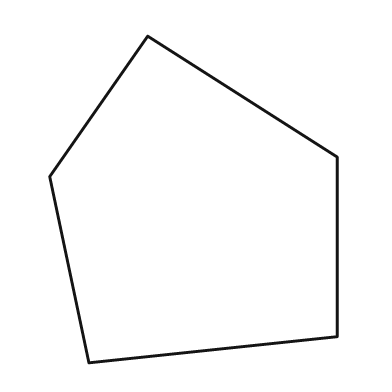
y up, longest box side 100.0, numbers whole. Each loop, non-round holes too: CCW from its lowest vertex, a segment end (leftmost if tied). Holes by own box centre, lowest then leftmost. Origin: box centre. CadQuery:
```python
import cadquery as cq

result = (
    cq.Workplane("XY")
    .moveTo(-32.0, -50.0)
    .lineTo(44.0, -42.0)
    .lineTo(44.0, 13.0)
    .lineTo(-14.0, 50.0)
    .lineTo(-44.0, 7.0)
    .close()
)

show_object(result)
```